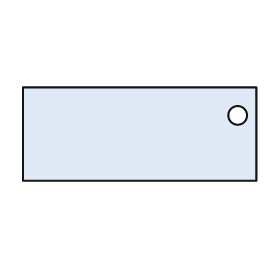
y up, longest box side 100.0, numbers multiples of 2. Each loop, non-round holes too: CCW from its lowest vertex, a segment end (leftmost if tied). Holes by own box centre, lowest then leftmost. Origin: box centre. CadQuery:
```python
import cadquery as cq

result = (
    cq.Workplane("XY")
    .moveTo(-50.0, -20.0)
    .lineTo(50.0, -20.0)
    .lineTo(50.0, 20.0)
    .lineTo(-50.0, 20.0)
    .close()
    .moveTo(42.0, 8.0)
    .circle(4.0)
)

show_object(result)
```